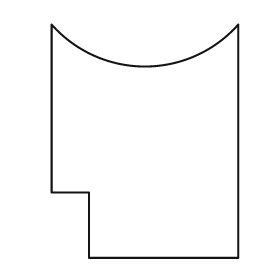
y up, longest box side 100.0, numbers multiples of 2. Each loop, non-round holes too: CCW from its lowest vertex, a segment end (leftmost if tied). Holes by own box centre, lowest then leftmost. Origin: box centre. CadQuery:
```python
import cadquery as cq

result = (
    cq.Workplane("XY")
    .moveTo(-24.0, -50.0)
    .lineTo(40.0, -50.0)
    .lineTo(40.0, 50.0)
    .threePointArc((0.0, 32.0), (-40.0, 50.0))
    .lineTo(-40.0, -22.0)
    .lineTo(-24.0, -22.0)
    .close()
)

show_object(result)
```